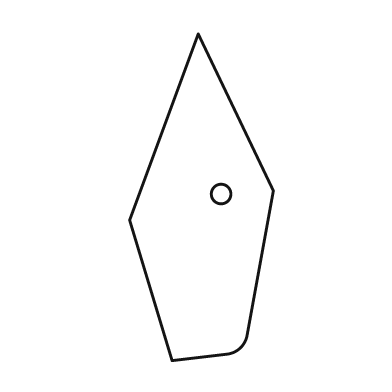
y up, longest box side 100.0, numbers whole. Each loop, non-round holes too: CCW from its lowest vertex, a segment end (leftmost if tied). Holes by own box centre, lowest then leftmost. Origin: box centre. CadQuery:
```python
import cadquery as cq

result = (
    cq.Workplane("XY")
    .moveTo(-9.0, -50.0)
    .lineTo(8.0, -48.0)
    .threePointArc((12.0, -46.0), (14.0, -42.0))
    .lineTo(22.0, 2.0)
    .lineTo(-1.0, 50.0)
    .lineTo(-22.0, -7.0)
    .close()
    .moveTo(6.0, 1.0)
    .circle(3.0)
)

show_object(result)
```